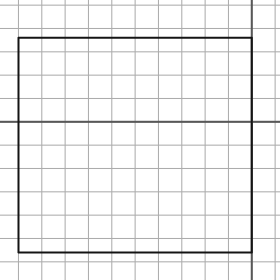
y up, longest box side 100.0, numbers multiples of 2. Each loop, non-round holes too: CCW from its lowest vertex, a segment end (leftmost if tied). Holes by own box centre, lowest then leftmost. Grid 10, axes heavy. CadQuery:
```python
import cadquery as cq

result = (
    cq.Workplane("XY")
    .moveTo(-100.0, -56.0)
    .lineTo(0.0, -56.0)
    .lineTo(0.0, 36.0)
    .lineTo(-100.0, 36.0)
    .close()
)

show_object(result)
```